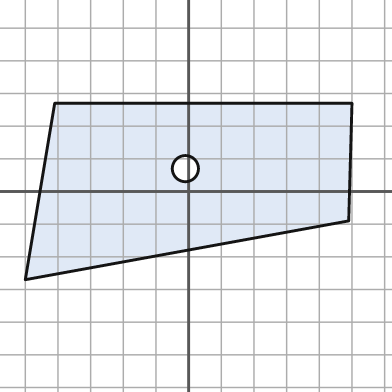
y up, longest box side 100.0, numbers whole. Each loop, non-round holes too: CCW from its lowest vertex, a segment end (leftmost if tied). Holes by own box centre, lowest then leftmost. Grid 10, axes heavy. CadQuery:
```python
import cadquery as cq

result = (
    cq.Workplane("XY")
    .moveTo(-50.0, -27.0)
    .lineTo(49.0, -9.0)
    .lineTo(50.0, 27.0)
    .lineTo(-41.0, 27.0)
    .close()
    .moveTo(-1.0, 7.0)
    .circle(4.0)
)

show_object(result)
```